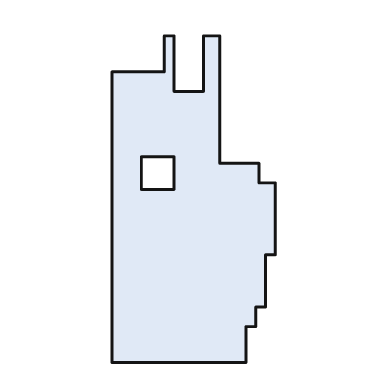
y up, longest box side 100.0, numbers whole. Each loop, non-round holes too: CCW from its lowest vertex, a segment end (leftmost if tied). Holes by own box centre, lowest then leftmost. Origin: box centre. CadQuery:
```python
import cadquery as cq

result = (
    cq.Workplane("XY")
    .moveTo(-25.0, -50.0)
    .lineTo(16.0, -50.0)
    .lineTo(16.0, -39.0)
    .lineTo(19.0, -39.0)
    .lineTo(19.0, -33.0)
    .lineTo(22.0, -33.0)
    .lineTo(22.0, -17.0)
    .lineTo(25.0, -17.0)
    .lineTo(25.0, 5.0)
    .lineTo(20.0, 5.0)
    .lineTo(20.0, 11.0)
    .lineTo(8.0, 11.0)
    .lineTo(8.0, 50.0)
    .lineTo(3.0, 50.0)
    .lineTo(3.0, 33.0)
    .lineTo(-6.0, 33.0)
    .lineTo(-6.0, 50.0)
    .lineTo(-9.0, 50.0)
    .lineTo(-9.0, 39.0)
    .lineTo(-25.0, 39.0)
    .close()
    .moveTo(-16.0, 3.0)
    .lineTo(-6.0, 3.0)
    .lineTo(-6.0, 13.0)
    .lineTo(-16.0, 13.0)
    .close()
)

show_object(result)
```